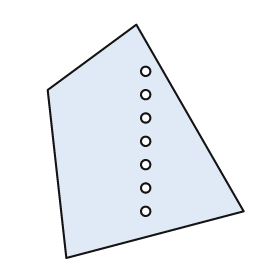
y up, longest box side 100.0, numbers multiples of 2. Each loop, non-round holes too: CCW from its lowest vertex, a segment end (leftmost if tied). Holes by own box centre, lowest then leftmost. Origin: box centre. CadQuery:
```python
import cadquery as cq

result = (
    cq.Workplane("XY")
    .moveTo(-34.0, -50.0)
    .lineTo(42.0, -30.0)
    .lineTo(-4.0, 50.0)
    .lineTo(-42.0, 22.0)
    .close()
    .moveTo(0.0, -30.0)
    .circle(2.0)
    .moveTo(0.0, -20.0)
    .circle(2.0)
    .moveTo(0.0, -10.0)
    .circle(2.0)
    .moveTo(0.0, 0.0)
    .circle(2.0)
    .moveTo(0.0, 10.0)
    .circle(2.0)
    .moveTo(0.0, 20.0)
    .circle(2.0)
    .moveTo(0.0, 30.0)
    .circle(2.0)
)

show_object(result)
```